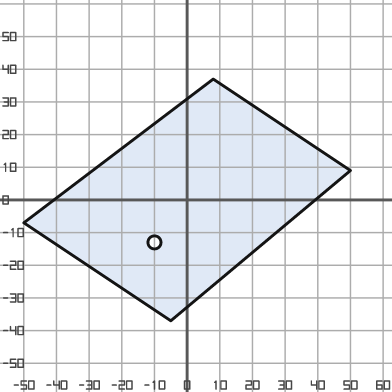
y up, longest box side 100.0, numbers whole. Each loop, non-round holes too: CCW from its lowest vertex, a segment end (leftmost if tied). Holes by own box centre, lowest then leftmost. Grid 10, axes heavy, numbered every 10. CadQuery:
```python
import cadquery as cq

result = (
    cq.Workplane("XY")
    .moveTo(-5.0, -37.0)
    .lineTo(50.0, 9.0)
    .lineTo(8.0, 37.0)
    .lineTo(-50.0, -7.0)
    .close()
    .moveTo(-10.0, -13.0)
    .circle(2.0)
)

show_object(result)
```